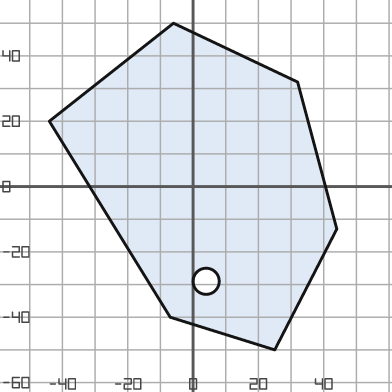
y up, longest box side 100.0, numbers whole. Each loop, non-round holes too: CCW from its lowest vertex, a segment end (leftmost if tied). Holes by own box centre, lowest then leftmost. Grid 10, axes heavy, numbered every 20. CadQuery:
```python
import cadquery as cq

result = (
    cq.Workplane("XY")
    .moveTo(25.0, -50.0)
    .lineTo(44.0, -13.0)
    .lineTo(32.0, 32.0)
    .lineTo(-6.0, 50.0)
    .lineTo(-44.0, 20.0)
    .lineTo(-7.0, -40.0)
    .close()
    .moveTo(4.0, -29.0)
    .circle(4.0)
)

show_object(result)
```